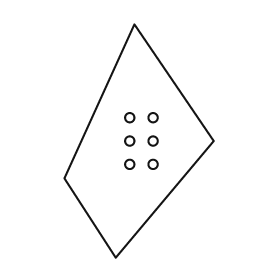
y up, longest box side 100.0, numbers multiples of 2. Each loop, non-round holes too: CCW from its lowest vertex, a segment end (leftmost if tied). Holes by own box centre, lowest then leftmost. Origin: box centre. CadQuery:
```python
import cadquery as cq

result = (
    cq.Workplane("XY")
    .moveTo(-10.0, -50.0)
    .lineTo(32.0, 0.0)
    .lineTo(-2.0, 50.0)
    .lineTo(-32.0, -16.0)
    .close()
    .moveTo(-4.0, -10.0)
    .circle(2.0)
    .moveTo(6.0, -10.0)
    .circle(2.0)
    .moveTo(-4.0, 0.0)
    .circle(2.0)
    .moveTo(6.0, 0.0)
    .circle(2.0)
    .moveTo(-4.0, 10.0)
    .circle(2.0)
    .moveTo(6.0, 10.0)
    .circle(2.0)
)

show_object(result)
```